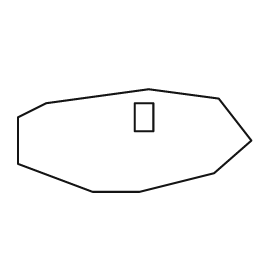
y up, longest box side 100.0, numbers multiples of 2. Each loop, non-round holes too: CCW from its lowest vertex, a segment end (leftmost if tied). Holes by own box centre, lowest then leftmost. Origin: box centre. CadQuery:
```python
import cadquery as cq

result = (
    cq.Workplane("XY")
    .moveTo(-18.0, -22.0)
    .lineTo(2.0, -22.0)
    .lineTo(34.0, -14.0)
    .lineTo(50.0, 0.0)
    .lineTo(36.0, 18.0)
    .lineTo(6.0, 22.0)
    .lineTo(-38.0, 16.0)
    .lineTo(-50.0, 10.0)
    .lineTo(-50.0, -10.0)
    .close()
    .moveTo(0.0, 4.0)
    .lineTo(8.0, 4.0)
    .lineTo(8.0, 16.0)
    .lineTo(0.0, 16.0)
    .close()
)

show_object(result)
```